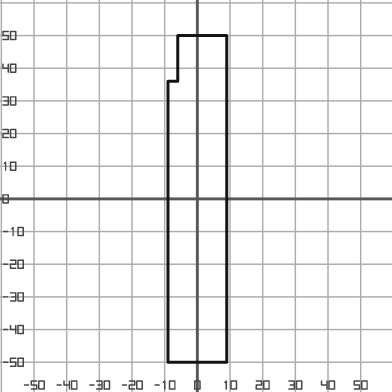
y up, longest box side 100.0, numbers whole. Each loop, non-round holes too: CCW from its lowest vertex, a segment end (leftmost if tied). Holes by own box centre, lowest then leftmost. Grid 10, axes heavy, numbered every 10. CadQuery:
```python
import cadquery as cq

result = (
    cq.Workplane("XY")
    .moveTo(-9.0, -50.0)
    .lineTo(9.0, -50.0)
    .lineTo(9.0, 50.0)
    .lineTo(-6.0, 50.0)
    .lineTo(-6.0, 36.0)
    .lineTo(-9.0, 36.0)
    .close()
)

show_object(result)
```